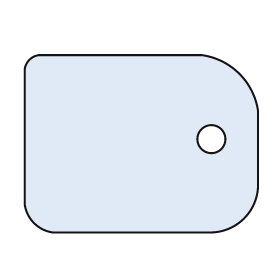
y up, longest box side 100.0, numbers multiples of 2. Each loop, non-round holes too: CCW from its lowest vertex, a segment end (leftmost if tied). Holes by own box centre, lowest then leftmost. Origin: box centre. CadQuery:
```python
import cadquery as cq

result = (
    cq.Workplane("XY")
    .moveTo(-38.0, -38.0)
    .lineTo(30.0, -38.0)
    .threePointArc((44.0, -32.0), (50.0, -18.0))
    .lineTo(50.0, 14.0)
    .threePointArc((42.0, 30.0), (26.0, 38.0))
    .lineTo(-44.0, 38.0)
    .threePointArc((-48.0, 36.0), (-50.0, 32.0))
    .lineTo(-50.0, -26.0)
    .threePointArc((-46.0, -34.0), (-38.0, -38.0))
    .close()
    .moveTo(30.0, 2.0)
    .circle(6.0)
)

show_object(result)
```